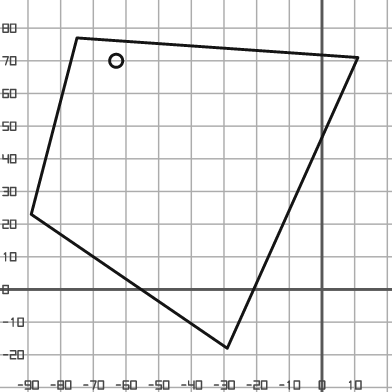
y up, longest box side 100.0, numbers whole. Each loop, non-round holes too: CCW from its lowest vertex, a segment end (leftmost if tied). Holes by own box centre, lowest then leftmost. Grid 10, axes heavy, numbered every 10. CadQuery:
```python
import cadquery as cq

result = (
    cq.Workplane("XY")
    .moveTo(-29.0, -18.0)
    .lineTo(11.0, 71.0)
    .lineTo(-75.0, 77.0)
    .lineTo(-89.0, 23.0)
    .close()
    .moveTo(-63.0, 70.0)
    .circle(2.0)
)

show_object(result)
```